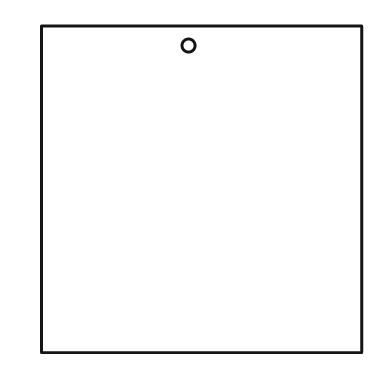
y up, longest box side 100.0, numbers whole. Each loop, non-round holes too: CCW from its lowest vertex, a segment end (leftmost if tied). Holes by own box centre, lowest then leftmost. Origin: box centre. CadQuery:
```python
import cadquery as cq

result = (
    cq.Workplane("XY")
    .moveTo(-49.0, -50.0)
    .lineTo(49.0, -50.0)
    .lineTo(49.0, 50.0)
    .lineTo(-49.0, 50.0)
    .close()
    .moveTo(-4.0, 44.0)
    .circle(2.0)
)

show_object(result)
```